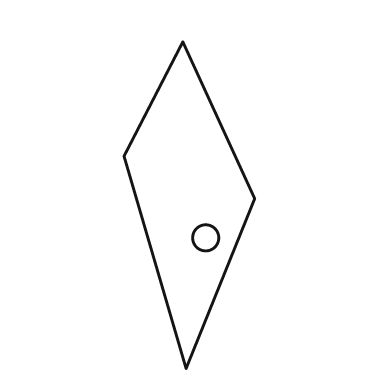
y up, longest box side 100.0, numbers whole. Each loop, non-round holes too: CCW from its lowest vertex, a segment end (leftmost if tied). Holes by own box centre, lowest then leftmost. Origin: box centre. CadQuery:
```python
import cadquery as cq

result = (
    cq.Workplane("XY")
    .moveTo(-1.0, -50.0)
    .lineTo(20.0, 2.0)
    .lineTo(-2.0, 50.0)
    .lineTo(-20.0, 15.0)
    .close()
    .moveTo(5.0, -10.0)
    .circle(4.0)
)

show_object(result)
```